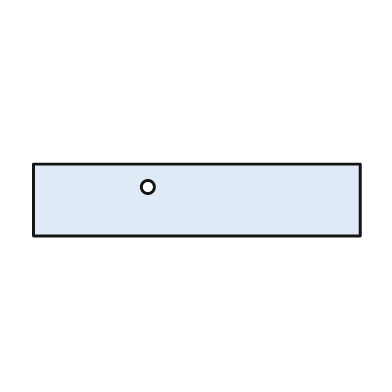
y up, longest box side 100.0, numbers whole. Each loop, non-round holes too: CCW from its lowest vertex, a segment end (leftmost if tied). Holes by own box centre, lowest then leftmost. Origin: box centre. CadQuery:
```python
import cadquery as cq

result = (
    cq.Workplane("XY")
    .moveTo(-50.0, -11.0)
    .lineTo(50.0, -11.0)
    .lineTo(50.0, 11.0)
    .lineTo(-50.0, 11.0)
    .close()
    .moveTo(-15.0, 4.0)
    .circle(2.0)
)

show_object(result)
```